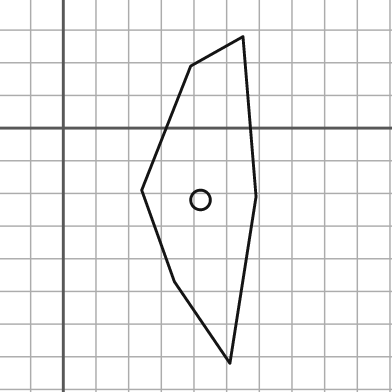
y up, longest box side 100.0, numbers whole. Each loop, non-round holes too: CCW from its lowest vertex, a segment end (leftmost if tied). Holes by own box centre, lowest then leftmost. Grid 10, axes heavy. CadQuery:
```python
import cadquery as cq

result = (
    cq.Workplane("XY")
    .moveTo(51.0, -72.0)
    .lineTo(59.0, -21.0)
    .lineTo(55.0, 28.0)
    .lineTo(39.0, 19.0)
    .lineTo(24.0, -19.0)
    .lineTo(34.0, -47.0)
    .close()
    .moveTo(42.0, -22.0)
    .circle(3.0)
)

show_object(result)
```